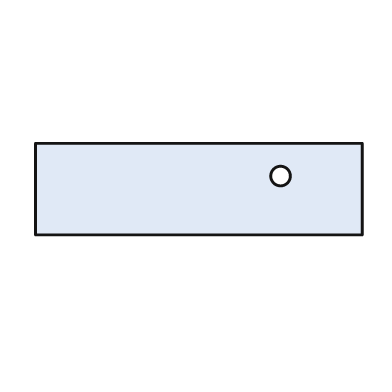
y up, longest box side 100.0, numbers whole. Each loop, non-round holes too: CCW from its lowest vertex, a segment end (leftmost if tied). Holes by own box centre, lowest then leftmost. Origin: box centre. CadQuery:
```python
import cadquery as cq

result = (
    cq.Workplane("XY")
    .moveTo(-50.0, -14.0)
    .lineTo(50.0, -14.0)
    .lineTo(50.0, 14.0)
    .lineTo(-50.0, 14.0)
    .close()
    .moveTo(25.0, 4.0)
    .circle(3.0)
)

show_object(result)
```